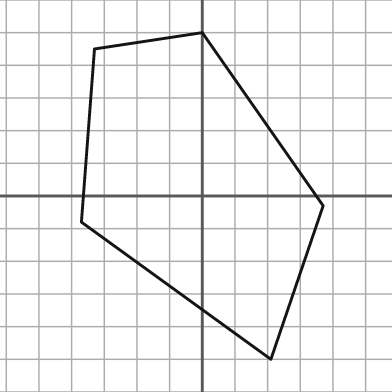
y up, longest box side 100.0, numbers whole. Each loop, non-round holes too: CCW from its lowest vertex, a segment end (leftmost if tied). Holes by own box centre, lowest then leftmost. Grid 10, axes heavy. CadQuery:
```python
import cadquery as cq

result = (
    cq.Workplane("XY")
    .moveTo(21.0, -50.0)
    .lineTo(37.0, -3.0)
    .lineTo(0.0, 50.0)
    .lineTo(-33.0, 45.0)
    .lineTo(-37.0, -8.0)
    .close()
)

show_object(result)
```